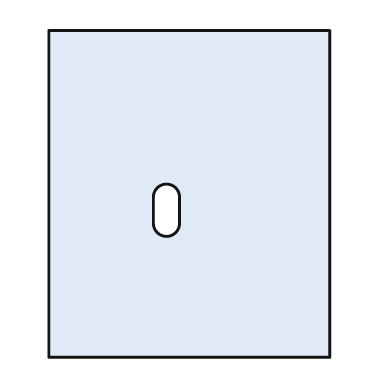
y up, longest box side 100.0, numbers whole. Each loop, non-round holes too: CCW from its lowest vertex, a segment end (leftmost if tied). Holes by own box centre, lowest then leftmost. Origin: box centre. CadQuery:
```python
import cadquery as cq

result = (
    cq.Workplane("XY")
    .moveTo(-43.0, -50.0)
    .lineTo(43.0, -50.0)
    .lineTo(43.0, 50.0)
    .lineTo(-43.0, 50.0)
    .close()
    .moveTo(-11.0, -9.0)
    .threePointArc((-7.0, -13.0), (-3.0, -9.0))
    .lineTo(-3.0, -1.0)
    .threePointArc((-7.0, 3.0), (-11.0, -1.0))
    .close()
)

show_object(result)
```